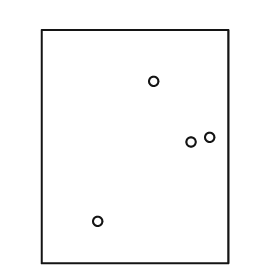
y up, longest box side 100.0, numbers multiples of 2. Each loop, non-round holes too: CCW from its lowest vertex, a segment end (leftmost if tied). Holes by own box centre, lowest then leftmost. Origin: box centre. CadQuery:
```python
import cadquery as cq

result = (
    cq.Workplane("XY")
    .moveTo(-40.0, -50.0)
    .lineTo(40.0, -50.0)
    .lineTo(40.0, 50.0)
    .lineTo(-40.0, 50.0)
    .close()
    .moveTo(-16.0, -32.0)
    .circle(2.0)
    .moveTo(24.0, 2.0)
    .circle(2.0)
    .moveTo(32.0, 4.0)
    .circle(2.0)
    .moveTo(8.0, 28.0)
    .circle(2.0)
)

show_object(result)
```